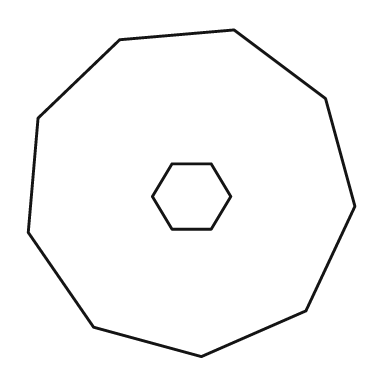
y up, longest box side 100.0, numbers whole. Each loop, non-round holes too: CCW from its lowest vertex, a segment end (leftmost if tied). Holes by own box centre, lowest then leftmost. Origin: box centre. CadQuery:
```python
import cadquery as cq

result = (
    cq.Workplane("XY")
    .moveTo(3.0, -50.0)
    .lineTo(35.0, -36.0)
    .lineTo(50.0, -4.0)
    .lineTo(41.0, 29.0)
    .lineTo(13.0, 50.0)
    .lineTo(-22.0, 47.0)
    .lineTo(-47.0, 23.0)
    .lineTo(-50.0, -12.0)
    .lineTo(-30.0, -41.0)
    .close()
    .moveTo(-6.0, -11.0)
    .lineTo(6.0, -11.0)
    .lineTo(12.0, -1.0)
    .lineTo(6.0, 9.0)
    .lineTo(-6.0, 9.0)
    .lineTo(-12.0, -1.0)
    .close()
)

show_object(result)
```